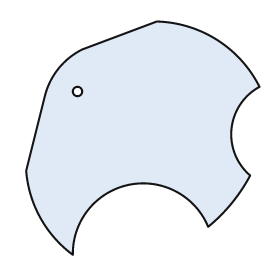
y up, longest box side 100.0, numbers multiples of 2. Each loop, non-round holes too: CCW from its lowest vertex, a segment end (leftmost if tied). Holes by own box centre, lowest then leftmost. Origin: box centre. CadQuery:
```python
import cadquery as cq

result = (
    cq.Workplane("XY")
    .moveTo(-30.0, -50.0)
    .threePointArc((-6.0, -20.0), (28.0, -38.0))
    .threePointArc((38.0, -28.0), (46.0, -16.0))
    .threePointArc((38.0, 4.0), (50.0, 22.0))
    .threePointArc((32.0, 42.0), (6.0, 50.0))
    .lineTo(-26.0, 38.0)
    .threePointArc((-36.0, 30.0), (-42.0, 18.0))
    .lineTo(-50.0, -14.0)
    .threePointArc((-44.0, -34.0), (-30.0, -50.0))
    .close()
    .moveTo(-28.0, 20.0)
    .circle(2.0)
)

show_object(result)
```